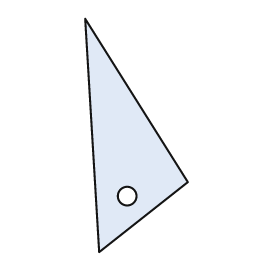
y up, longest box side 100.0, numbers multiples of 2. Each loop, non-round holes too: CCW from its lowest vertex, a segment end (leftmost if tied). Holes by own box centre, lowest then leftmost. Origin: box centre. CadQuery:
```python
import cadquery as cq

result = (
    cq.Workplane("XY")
    .moveTo(-16.0, -50.0)
    .lineTo(22.0, -20.0)
    .lineTo(-22.0, 50.0)
    .close()
    .moveTo(-4.0, -26.0)
    .circle(4.0)
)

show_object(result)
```